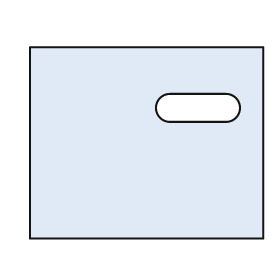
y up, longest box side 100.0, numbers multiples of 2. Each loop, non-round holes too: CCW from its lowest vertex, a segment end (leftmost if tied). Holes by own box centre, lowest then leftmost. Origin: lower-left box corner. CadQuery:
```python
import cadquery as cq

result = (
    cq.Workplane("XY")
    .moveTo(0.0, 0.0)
    .lineTo(100.0, 0.0)
    .lineTo(100.0, 82.0)
    .lineTo(0.0, 82.0)
    .close()
    .moveTo(60.0, 50.0)
    .lineTo(84.0, 50.0)
    .threePointArc((90.0, 56.0), (84.0, 62.0))
    .lineTo(60.0, 62.0)
    .threePointArc((54.0, 56.0), (60.0, 50.0))
    .close()
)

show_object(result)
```